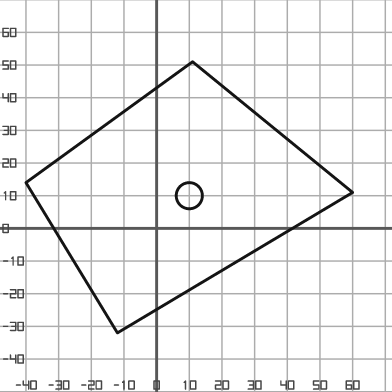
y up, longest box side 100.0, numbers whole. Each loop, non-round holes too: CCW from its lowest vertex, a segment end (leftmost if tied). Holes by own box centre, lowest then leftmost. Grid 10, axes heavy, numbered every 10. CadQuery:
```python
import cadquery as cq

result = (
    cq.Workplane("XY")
    .moveTo(-12.0, -32.0)
    .lineTo(60.0, 11.0)
    .lineTo(11.0, 51.0)
    .lineTo(-40.0, 14.0)
    .close()
    .moveTo(10.0, 10.0)
    .circle(4.0)
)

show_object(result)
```